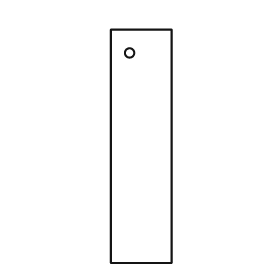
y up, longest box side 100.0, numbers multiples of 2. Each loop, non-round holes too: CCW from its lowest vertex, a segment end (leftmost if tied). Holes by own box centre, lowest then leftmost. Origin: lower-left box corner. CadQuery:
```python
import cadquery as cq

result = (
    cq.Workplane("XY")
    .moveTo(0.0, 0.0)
    .lineTo(26.0, 0.0)
    .lineTo(26.0, 100.0)
    .lineTo(0.0, 100.0)
    .close()
    .moveTo(8.0, 90.0)
    .circle(2.0)
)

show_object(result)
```